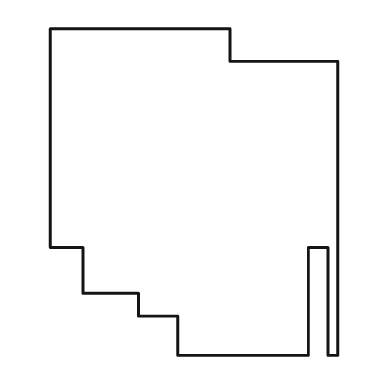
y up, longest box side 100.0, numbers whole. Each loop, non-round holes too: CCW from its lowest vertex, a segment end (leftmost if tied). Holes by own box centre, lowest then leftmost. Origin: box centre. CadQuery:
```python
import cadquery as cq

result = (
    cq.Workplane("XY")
    .moveTo(-5.0, -50.0)
    .lineTo(35.0, -50.0)
    .lineTo(35.0, -17.0)
    .lineTo(41.0, -17.0)
    .lineTo(41.0, -50.0)
    .lineTo(44.0, -50.0)
    .lineTo(44.0, 40.0)
    .lineTo(11.0, 40.0)
    .lineTo(11.0, 50.0)
    .lineTo(-44.0, 50.0)
    .lineTo(-44.0, -17.0)
    .lineTo(-34.0, -17.0)
    .lineTo(-34.0, -31.0)
    .lineTo(-17.0, -31.0)
    .lineTo(-17.0, -38.0)
    .lineTo(-5.0, -38.0)
    .close()
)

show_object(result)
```